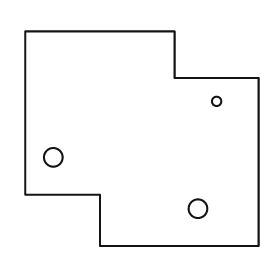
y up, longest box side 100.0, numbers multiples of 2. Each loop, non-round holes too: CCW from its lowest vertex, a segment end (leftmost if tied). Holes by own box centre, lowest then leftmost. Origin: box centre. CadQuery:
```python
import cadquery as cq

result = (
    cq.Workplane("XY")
    .moveTo(-18.0, -46.0)
    .lineTo(50.0, -46.0)
    .lineTo(50.0, 26.0)
    .lineTo(14.0, 26.0)
    .lineTo(14.0, 46.0)
    .lineTo(-50.0, 46.0)
    .lineTo(-50.0, -24.0)
    .lineTo(-18.0, -24.0)
    .close()
    .moveTo(24.0, -30.0)
    .circle(4.0)
    .moveTo(-38.0, -8.0)
    .circle(4.0)
    .moveTo(32.0, 16.0)
    .circle(2.0)
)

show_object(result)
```